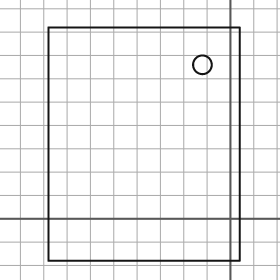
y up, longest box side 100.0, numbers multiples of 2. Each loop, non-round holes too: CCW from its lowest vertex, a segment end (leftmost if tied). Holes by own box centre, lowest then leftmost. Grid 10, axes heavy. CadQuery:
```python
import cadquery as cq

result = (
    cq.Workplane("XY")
    .moveTo(-78.0, -18.0)
    .lineTo(4.0, -18.0)
    .lineTo(4.0, 82.0)
    .lineTo(-78.0, 82.0)
    .close()
    .moveTo(-12.0, 66.0)
    .circle(4.0)
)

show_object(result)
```